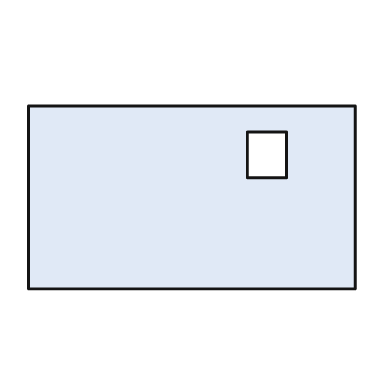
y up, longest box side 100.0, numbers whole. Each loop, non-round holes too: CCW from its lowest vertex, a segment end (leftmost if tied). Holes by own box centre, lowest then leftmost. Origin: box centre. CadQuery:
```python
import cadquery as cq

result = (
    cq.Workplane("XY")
    .moveTo(-50.0, -28.0)
    .lineTo(50.0, -28.0)
    .lineTo(50.0, 28.0)
    .lineTo(-50.0, 28.0)
    .close()
    .moveTo(17.0, 6.0)
    .lineTo(29.0, 6.0)
    .lineTo(29.0, 20.0)
    .lineTo(17.0, 20.0)
    .close()
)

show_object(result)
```